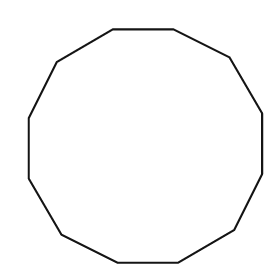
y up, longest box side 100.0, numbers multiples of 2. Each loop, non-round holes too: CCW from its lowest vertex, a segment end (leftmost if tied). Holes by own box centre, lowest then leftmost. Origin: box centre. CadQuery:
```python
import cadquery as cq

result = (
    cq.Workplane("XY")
    .moveTo(-12.0, -50.0)
    .lineTo(14.0, -50.0)
    .lineTo(38.0, -36.0)
    .lineTo(50.0, -12.0)
    .lineTo(50.0, 14.0)
    .lineTo(36.0, 38.0)
    .lineTo(12.0, 50.0)
    .lineTo(-14.0, 50.0)
    .lineTo(-38.0, 36.0)
    .lineTo(-50.0, 12.0)
    .lineTo(-50.0, -14.0)
    .lineTo(-36.0, -38.0)
    .close()
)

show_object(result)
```